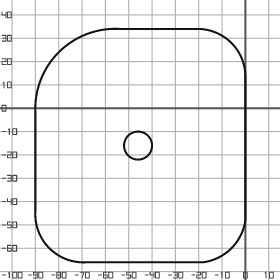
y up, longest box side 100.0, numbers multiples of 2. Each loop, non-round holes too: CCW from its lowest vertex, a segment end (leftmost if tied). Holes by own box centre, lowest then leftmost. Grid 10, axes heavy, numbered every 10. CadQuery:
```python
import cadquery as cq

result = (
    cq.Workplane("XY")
    .moveTo(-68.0, -66.0)
    .lineTo(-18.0, -66.0)
    .threePointArc((-6.0, -60.0), (0.0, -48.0))
    .lineTo(0.0, 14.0)
    .threePointArc((-6.0, 28.0), (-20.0, 34.0))
    .lineTo(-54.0, 34.0)
    .threePointArc((-80.0, 24.0), (-90.0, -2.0))
    .lineTo(-90.0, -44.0)
    .threePointArc((-84.0, -60.0), (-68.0, -66.0))
    .close()
    .moveTo(-46.0, -16.0)
    .circle(6.0)
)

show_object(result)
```